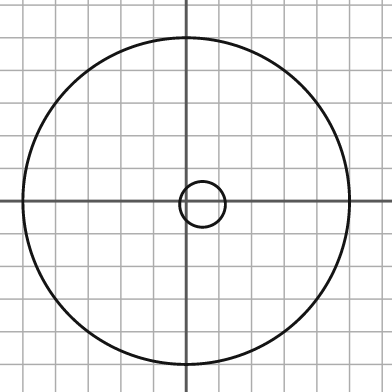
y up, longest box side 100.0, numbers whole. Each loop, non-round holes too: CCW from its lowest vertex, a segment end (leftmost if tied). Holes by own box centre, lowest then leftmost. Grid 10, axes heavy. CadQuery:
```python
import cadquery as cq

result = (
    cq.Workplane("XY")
    .moveTo(0.0, 0.0)
    .circle(50.0)
    .moveTo(5.0, -1.0)
    .circle(7.0)
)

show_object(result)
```